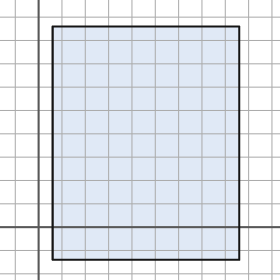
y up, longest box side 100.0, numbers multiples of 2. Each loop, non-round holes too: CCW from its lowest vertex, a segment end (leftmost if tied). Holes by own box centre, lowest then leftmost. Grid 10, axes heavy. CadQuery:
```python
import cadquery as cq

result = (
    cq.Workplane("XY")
    .moveTo(6.0, -14.0)
    .lineTo(86.0, -14.0)
    .lineTo(86.0, 86.0)
    .lineTo(6.0, 86.0)
    .close()
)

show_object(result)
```